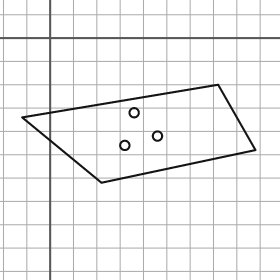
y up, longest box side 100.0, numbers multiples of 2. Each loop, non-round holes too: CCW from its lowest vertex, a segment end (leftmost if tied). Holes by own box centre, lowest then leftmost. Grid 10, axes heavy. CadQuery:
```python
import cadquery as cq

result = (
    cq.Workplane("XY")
    .moveTo(22.0, -62.0)
    .lineTo(88.0, -48.0)
    .lineTo(72.0, -20.0)
    .lineTo(-12.0, -34.0)
    .close()
    .moveTo(32.0, -46.0)
    .circle(2.0)
    .moveTo(46.0, -42.0)
    .circle(2.0)
    .moveTo(36.0, -32.0)
    .circle(2.0)
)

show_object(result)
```